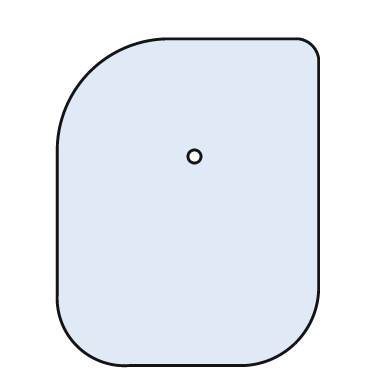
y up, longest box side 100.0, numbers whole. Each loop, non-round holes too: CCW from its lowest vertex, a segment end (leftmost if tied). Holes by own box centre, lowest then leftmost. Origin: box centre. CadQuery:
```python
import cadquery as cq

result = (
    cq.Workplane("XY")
    .moveTo(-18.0, -50.0)
    .lineTo(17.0, -50.0)
    .threePointArc((33.0, -43.0), (40.0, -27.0))
    .lineTo(40.0, 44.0)
    .threePointArc((38.0, 48.0), (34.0, 50.0))
    .lineTo(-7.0, 50.0)
    .threePointArc((-30.0, 40.0), (-40.0, 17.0))
    .lineTo(-40.0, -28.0)
    .threePointArc((-34.0, -44.0), (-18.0, -50.0))
    .close()
    .moveTo(2.0, 14.0)
    .circle(2.0)
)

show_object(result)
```